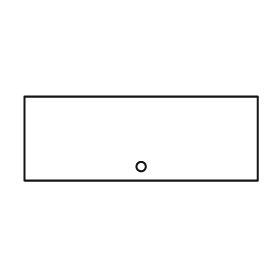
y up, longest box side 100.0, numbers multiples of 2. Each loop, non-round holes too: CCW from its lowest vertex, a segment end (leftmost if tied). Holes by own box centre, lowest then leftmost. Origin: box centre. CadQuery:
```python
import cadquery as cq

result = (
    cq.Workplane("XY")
    .moveTo(-50.0, -18.0)
    .lineTo(50.0, -18.0)
    .lineTo(50.0, 18.0)
    .lineTo(-50.0, 18.0)
    .close()
    .moveTo(0.0, -12.0)
    .circle(2.0)
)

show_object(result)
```